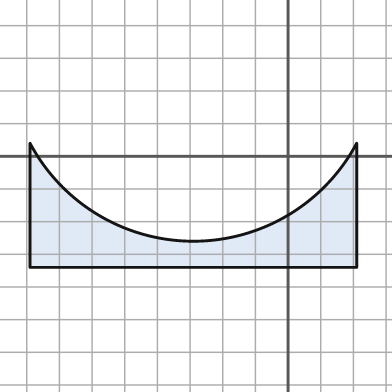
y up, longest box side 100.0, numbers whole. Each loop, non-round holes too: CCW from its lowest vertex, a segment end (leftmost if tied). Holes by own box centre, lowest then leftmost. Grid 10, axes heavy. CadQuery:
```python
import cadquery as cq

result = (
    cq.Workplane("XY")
    .moveTo(-79.0, -34.0)
    .lineTo(21.0, -34.0)
    .lineTo(21.0, 4.0)
    .threePointArc((-29.0, -26.0), (-79.0, 4.0))
    .close()
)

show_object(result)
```